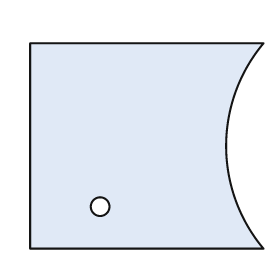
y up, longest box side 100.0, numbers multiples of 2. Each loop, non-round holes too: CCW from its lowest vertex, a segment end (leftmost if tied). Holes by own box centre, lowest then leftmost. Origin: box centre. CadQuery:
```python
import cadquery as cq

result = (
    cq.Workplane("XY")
    .moveTo(-50.0, -44.0)
    .lineTo(50.0, -44.0)
    .threePointArc((34.0, 0.0), (50.0, 44.0))
    .lineTo(-50.0, 44.0)
    .close()
    .moveTo(-20.0, -26.0)
    .circle(4.0)
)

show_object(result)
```